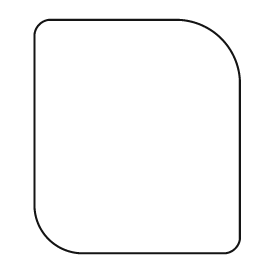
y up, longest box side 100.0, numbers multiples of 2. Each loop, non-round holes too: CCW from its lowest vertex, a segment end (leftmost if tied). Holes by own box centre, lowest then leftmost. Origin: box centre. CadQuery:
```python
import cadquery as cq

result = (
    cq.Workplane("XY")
    .moveTo(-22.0, -50.0)
    .lineTo(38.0, -50.0)
    .threePointArc((42.0, -48.0), (44.0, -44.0))
    .lineTo(44.0, 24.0)
    .threePointArc((36.0, 42.0), (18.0, 50.0))
    .lineTo(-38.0, 50.0)
    .threePointArc((-42.0, 48.0), (-44.0, 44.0))
    .lineTo(-44.0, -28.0)
    .threePointArc((-38.0, -44.0), (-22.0, -50.0))
    .close()
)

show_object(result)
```